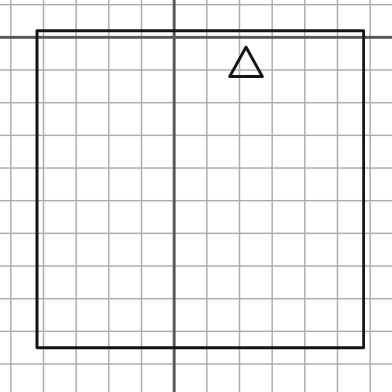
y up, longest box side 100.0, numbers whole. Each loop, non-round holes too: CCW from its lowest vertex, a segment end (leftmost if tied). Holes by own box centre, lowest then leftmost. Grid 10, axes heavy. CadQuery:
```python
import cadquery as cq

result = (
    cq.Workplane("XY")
    .moveTo(-42.0, -95.0)
    .lineTo(58.0, -95.0)
    .lineTo(58.0, 2.0)
    .lineTo(-42.0, 2.0)
    .close()
    .moveTo(17.0, -12.0)
    .lineTo(27.0, -12.0)
    .lineTo(22.0, -3.0)
    .close()
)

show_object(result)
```